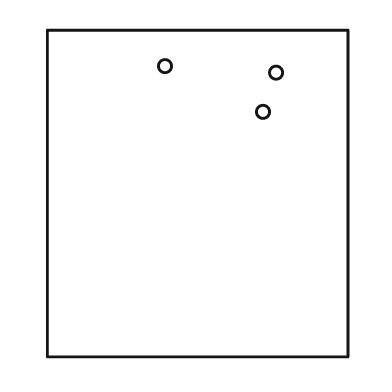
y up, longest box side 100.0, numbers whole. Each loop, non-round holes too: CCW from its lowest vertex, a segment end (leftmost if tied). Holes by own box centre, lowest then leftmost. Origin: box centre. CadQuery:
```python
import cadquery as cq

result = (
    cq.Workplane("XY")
    .moveTo(-46.0, -50.0)
    .lineTo(46.0, -50.0)
    .lineTo(46.0, 50.0)
    .lineTo(-46.0, 50.0)
    .close()
    .moveTo(20.0, 25.0)
    .circle(2.0)
    .moveTo(24.0, 37.0)
    .circle(2.0)
    .moveTo(-10.0, 39.0)
    .circle(2.0)
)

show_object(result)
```